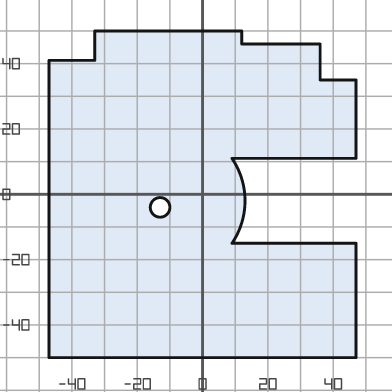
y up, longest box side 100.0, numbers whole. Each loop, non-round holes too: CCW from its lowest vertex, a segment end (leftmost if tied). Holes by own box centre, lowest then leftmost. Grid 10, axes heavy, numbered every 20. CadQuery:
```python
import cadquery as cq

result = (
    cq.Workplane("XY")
    .moveTo(-47.0, -50.0)
    .lineTo(47.0, -50.0)
    .lineTo(47.0, -15.0)
    .lineTo(9.0, -15.0)
    .threePointArc((13.0, -2.0), (9.0, 11.0))
    .lineTo(47.0, 11.0)
    .lineTo(47.0, 35.0)
    .lineTo(36.0, 35.0)
    .lineTo(36.0, 46.0)
    .lineTo(12.0, 46.0)
    .lineTo(12.0, 50.0)
    .lineTo(-33.0, 50.0)
    .lineTo(-33.0, 41.0)
    .lineTo(-47.0, 41.0)
    .close()
    .moveTo(-13.0, -4.0)
    .circle(3.0)
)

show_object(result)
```